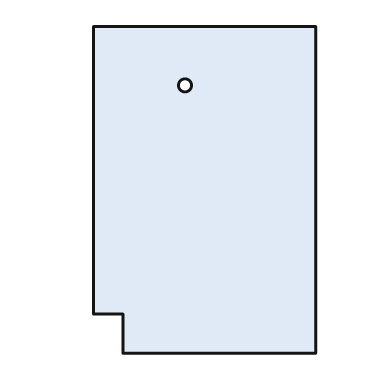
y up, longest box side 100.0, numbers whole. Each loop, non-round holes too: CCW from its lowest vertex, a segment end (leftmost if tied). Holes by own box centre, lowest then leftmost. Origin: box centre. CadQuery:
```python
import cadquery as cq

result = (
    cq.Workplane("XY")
    .moveTo(-25.0, -50.0)
    .lineTo(34.0, -50.0)
    .lineTo(34.0, 50.0)
    .lineTo(-34.0, 50.0)
    .lineTo(-34.0, -38.0)
    .lineTo(-25.0, -38.0)
    .close()
    .moveTo(-6.0, 32.0)
    .circle(2.0)
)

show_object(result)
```